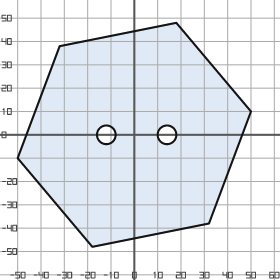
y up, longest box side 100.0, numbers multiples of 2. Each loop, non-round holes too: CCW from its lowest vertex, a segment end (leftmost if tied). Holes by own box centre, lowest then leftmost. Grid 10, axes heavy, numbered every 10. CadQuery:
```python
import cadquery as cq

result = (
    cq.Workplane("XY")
    .moveTo(-18.0, -48.0)
    .lineTo(32.0, -38.0)
    .lineTo(50.0, 10.0)
    .lineTo(18.0, 48.0)
    .lineTo(-32.0, 38.0)
    .lineTo(-50.0, -10.0)
    .close()
    .moveTo(-12.0, 0.0)
    .circle(4.0)
    .moveTo(14.0, 0.0)
    .circle(4.0)
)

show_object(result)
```